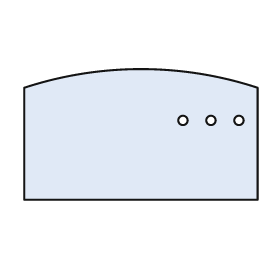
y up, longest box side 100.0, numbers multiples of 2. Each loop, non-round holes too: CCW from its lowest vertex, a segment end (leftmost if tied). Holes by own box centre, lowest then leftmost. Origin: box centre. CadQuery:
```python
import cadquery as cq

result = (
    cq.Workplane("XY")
    .moveTo(-50.0, -28.0)
    .lineTo(50.0, -28.0)
    .lineTo(50.0, 20.0)
    .threePointArc((0.0, 28.0), (-50.0, 20.0))
    .close()
    .moveTo(18.0, 6.0)
    .circle(2.0)
    .moveTo(30.0, 6.0)
    .circle(2.0)
    .moveTo(42.0, 6.0)
    .circle(2.0)
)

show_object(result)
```